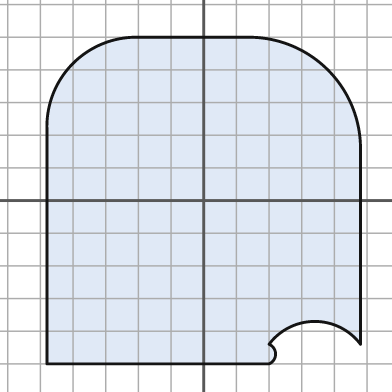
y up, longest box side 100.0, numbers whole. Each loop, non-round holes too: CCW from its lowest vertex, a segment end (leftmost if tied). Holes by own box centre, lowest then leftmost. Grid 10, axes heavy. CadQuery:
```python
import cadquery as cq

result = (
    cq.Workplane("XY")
    .moveTo(-48.0, -50.0)
    .lineTo(20.0, -50.0)
    .threePointArc((22.0, -47.0), (20.0, -44.0))
    .threePointArc((34.0, -37.0), (48.0, -44.0))
    .lineTo(48.0, 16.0)
    .threePointArc((38.0, 40.0), (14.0, 50.0))
    .lineTo(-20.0, 50.0)
    .threePointArc((-40.0, 42.0), (-48.0, 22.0))
    .close()
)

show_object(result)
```